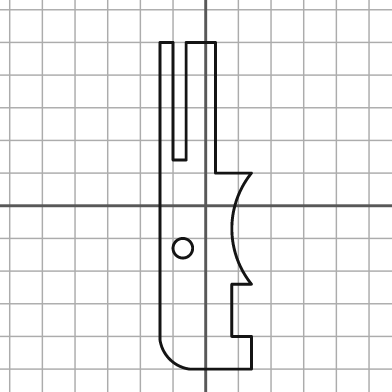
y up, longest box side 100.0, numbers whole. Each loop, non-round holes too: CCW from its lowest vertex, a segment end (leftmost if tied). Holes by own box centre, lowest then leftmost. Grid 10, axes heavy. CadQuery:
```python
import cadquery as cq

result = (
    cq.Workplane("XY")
    .moveTo(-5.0, -50.0)
    .lineTo(14.0, -50.0)
    .lineTo(14.0, -40.0)
    .lineTo(8.0, -40.0)
    .lineTo(8.0, -24.0)
    .lineTo(14.0, -24.0)
    .threePointArc((8.0, -7.0), (14.0, 10.0))
    .lineTo(3.0, 10.0)
    .lineTo(3.0, 50.0)
    .lineTo(-6.0, 50.0)
    .lineTo(-6.0, 14.0)
    .lineTo(-10.0, 14.0)
    .lineTo(-10.0, 50.0)
    .lineTo(-14.0, 50.0)
    .lineTo(-14.0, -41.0)
    .threePointArc((-11.0, -47.0), (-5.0, -50.0))
    .close()
    .moveTo(-7.0, -13.0)
    .circle(3.0)
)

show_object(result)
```